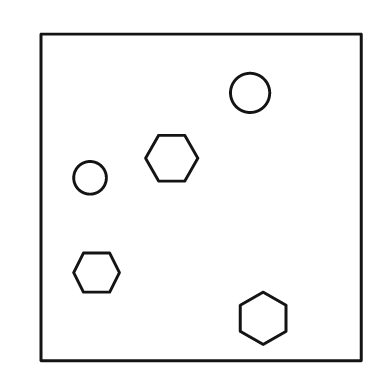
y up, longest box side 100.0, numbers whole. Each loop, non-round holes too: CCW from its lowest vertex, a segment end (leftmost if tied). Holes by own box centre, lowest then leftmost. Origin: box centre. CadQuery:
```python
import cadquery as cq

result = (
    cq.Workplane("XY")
    .moveTo(-49.0, -50.0)
    .lineTo(49.0, -50.0)
    .lineTo(49.0, 50.0)
    .lineTo(-49.0, 50.0)
    .close()
    .moveTo(19.0, -45.0)
    .lineTo(26.0, -41.0)
    .lineTo(26.0, -33.0)
    .lineTo(19.0, -29.0)
    .lineTo(12.0, -33.0)
    .lineTo(12.0, -41.0)
    .close()
    .moveTo(-36.0, -29.0)
    .lineTo(-28.0, -29.0)
    .lineTo(-25.0, -23.0)
    .lineTo(-28.0, -17.0)
    .lineTo(-36.0, -17.0)
    .lineTo(-39.0, -23.0)
    .close()
    .moveTo(-34.0, 6.0)
    .circle(5.0)
    .moveTo(-13.0, 5.0)
    .lineTo(-5.0, 5.0)
    .lineTo(-1.0, 12.0)
    .lineTo(-5.0, 19.0)
    .lineTo(-13.0, 19.0)
    .lineTo(-17.0, 12.0)
    .close()
    .moveTo(15.0, 32.0)
    .circle(6.0)
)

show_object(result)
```